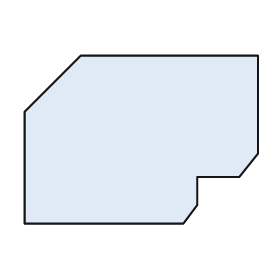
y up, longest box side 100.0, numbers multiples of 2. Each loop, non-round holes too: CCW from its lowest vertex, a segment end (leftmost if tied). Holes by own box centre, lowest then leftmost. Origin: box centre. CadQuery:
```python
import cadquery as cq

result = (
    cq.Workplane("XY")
    .moveTo(-50.0, -36.0)
    .lineTo(18.0, -36.0)
    .lineTo(24.0, -28.0)
    .lineTo(24.0, -16.0)
    .lineTo(42.0, -16.0)
    .lineTo(50.0, -6.0)
    .lineTo(50.0, 36.0)
    .lineTo(-26.0, 36.0)
    .lineTo(-50.0, 12.0)
    .close()
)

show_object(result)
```